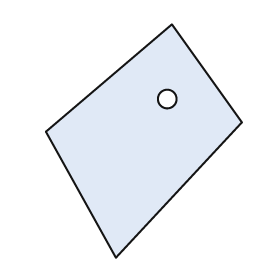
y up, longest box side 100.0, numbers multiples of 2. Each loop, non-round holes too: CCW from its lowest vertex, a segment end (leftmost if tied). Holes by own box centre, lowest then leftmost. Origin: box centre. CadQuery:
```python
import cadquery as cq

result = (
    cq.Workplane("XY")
    .moveTo(-12.0, -50.0)
    .lineTo(42.0, 8.0)
    .lineTo(12.0, 50.0)
    .lineTo(-42.0, 4.0)
    .close()
    .moveTo(10.0, 18.0)
    .circle(4.0)
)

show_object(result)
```